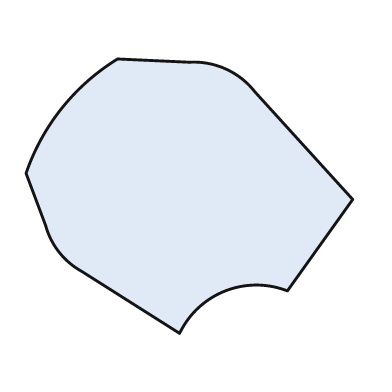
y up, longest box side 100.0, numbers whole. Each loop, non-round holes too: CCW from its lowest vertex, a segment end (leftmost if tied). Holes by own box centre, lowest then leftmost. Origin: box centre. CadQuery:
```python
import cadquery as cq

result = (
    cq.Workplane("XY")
    .moveTo(-3.0, -42.0)
    .threePointArc((11.0, -29.0), (30.0, -29.0))
    .lineTo(50.0, -1.0)
    .lineTo(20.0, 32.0)
    .threePointArc((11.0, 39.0), (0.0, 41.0))
    .lineTo(-22.0, 42.0)
    .threePointArc((-39.0, 27.0), (-50.0, 7.0))
    .lineTo(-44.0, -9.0)
    .threePointArc((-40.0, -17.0), (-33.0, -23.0))
    .close()
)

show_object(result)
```